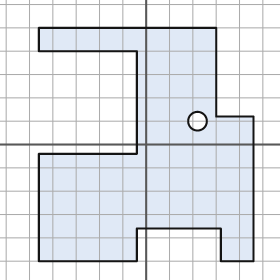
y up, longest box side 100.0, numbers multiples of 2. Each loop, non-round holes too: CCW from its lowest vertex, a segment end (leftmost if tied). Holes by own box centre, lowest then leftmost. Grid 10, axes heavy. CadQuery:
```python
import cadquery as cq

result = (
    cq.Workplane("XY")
    .moveTo(-46.0, -50.0)
    .lineTo(-4.0, -50.0)
    .lineTo(-4.0, -36.0)
    .lineTo(32.0, -36.0)
    .lineTo(32.0, -50.0)
    .lineTo(46.0, -50.0)
    .lineTo(46.0, 12.0)
    .lineTo(30.0, 12.0)
    .lineTo(30.0, 50.0)
    .lineTo(-46.0, 50.0)
    .lineTo(-46.0, 40.0)
    .lineTo(-4.0, 40.0)
    .lineTo(-4.0, -4.0)
    .lineTo(-46.0, -4.0)
    .close()
    .moveTo(22.0, 10.0)
    .circle(4.0)
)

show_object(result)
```